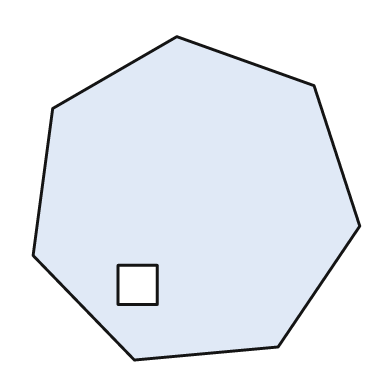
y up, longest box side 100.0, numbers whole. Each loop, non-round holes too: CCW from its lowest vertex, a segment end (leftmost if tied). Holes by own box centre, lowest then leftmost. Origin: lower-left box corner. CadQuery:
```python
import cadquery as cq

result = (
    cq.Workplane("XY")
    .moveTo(31.0, 0.0)
    .lineTo(75.0, 4.0)
    .lineTo(100.0, 41.0)
    .lineTo(86.0, 84.0)
    .lineTo(44.0, 99.0)
    .lineTo(6.0, 77.0)
    .lineTo(0.0, 32.0)
    .close()
    .moveTo(26.0, 17.0)
    .lineTo(38.0, 17.0)
    .lineTo(38.0, 29.0)
    .lineTo(26.0, 29.0)
    .close()
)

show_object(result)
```